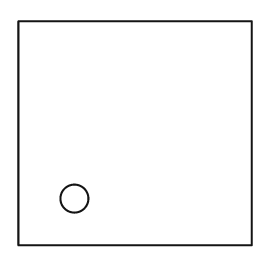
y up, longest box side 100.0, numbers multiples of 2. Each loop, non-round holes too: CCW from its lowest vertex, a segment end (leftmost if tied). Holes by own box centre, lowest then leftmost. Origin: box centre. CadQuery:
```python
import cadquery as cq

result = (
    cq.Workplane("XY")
    .moveTo(-50.0, -48.0)
    .lineTo(50.0, -48.0)
    .lineTo(50.0, 48.0)
    .lineTo(-50.0, 48.0)
    .close()
    .moveTo(-26.0, -28.0)
    .circle(6.0)
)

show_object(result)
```